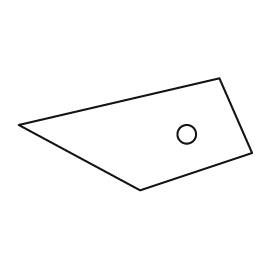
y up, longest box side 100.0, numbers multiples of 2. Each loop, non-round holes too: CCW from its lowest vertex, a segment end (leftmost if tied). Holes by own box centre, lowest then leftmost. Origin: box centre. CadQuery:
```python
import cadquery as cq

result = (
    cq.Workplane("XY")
    .moveTo(2.0, -24.0)
    .lineTo(50.0, -8.0)
    .lineTo(36.0, 24.0)
    .lineTo(-50.0, 4.0)
    .close()
    .moveTo(22.0, 0.0)
    .circle(4.0)
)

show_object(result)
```